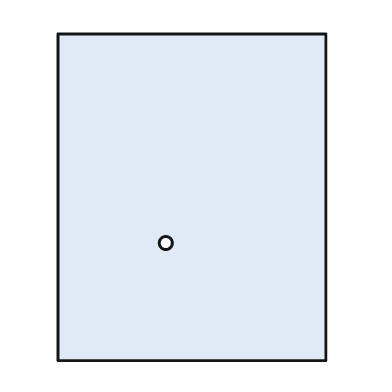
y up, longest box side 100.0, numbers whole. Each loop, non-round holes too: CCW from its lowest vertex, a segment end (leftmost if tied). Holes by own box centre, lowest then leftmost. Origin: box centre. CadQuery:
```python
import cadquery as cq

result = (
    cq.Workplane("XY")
    .moveTo(-41.0, -50.0)
    .lineTo(41.0, -50.0)
    .lineTo(41.0, 50.0)
    .lineTo(-41.0, 50.0)
    .close()
    .moveTo(-8.0, -14.0)
    .circle(2.0)
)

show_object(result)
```